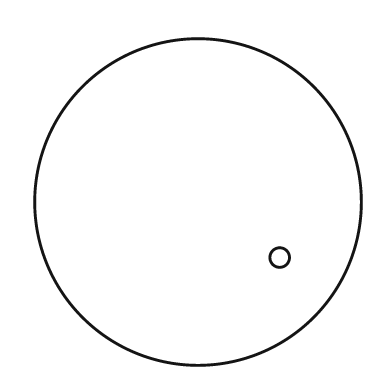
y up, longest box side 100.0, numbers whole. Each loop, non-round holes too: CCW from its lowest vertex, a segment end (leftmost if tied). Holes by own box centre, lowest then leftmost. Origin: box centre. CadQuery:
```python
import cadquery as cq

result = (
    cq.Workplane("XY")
    .moveTo(0.0, 0.0)
    .circle(50.0)
    .moveTo(25.0, -17.0)
    .circle(3.0)
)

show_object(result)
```